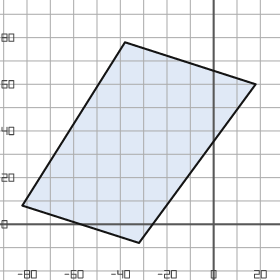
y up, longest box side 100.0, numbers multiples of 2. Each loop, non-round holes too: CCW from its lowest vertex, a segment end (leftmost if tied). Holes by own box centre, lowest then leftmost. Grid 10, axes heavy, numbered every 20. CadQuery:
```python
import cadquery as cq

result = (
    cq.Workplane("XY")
    .moveTo(-32.0, -8.0)
    .lineTo(18.0, 60.0)
    .lineTo(-38.0, 78.0)
    .lineTo(-82.0, 8.0)
    .close()
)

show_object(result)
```